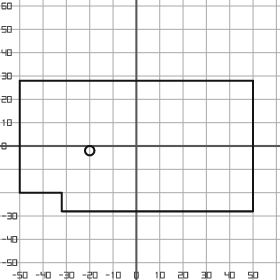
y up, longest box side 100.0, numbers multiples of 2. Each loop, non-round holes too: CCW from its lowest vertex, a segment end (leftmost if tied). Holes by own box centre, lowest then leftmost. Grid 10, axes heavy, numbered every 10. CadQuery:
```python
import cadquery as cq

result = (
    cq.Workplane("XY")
    .moveTo(-32.0, -28.0)
    .lineTo(50.0, -28.0)
    .lineTo(50.0, 28.0)
    .lineTo(-50.0, 28.0)
    .lineTo(-50.0, -20.0)
    .lineTo(-32.0, -20.0)
    .close()
    .moveTo(-20.0, -2.0)
    .circle(2.0)
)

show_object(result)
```